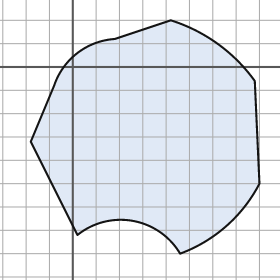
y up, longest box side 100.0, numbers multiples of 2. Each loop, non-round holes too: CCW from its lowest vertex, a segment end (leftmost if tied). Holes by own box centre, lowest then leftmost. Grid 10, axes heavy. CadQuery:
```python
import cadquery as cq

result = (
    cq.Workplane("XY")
    .moveTo(46.0, -80.0)
    .threePointArc((66.0, -68.0), (80.0, -50.0))
    .lineTo(78.0, -6.0)
    .threePointArc((62.0, 10.0), (42.0, 20.0))
    .lineTo(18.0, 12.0)
    .threePointArc((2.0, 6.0), (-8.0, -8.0))
    .lineTo(-18.0, -32.0)
    .lineTo(2.0, -72.0)
    .threePointArc((26.0, -66.0), (46.0, -80.0))
    .close()
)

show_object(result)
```